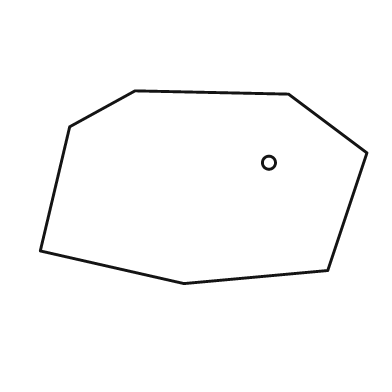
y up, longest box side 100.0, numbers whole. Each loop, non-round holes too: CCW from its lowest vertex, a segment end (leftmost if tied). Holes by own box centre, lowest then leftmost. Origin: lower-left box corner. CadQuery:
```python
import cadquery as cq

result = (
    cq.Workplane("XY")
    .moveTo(44.0, 0.0)
    .lineTo(88.0, 4.0)
    .lineTo(100.0, 40.0)
    .lineTo(76.0, 58.0)
    .lineTo(29.0, 59.0)
    .lineTo(9.0, 48.0)
    .lineTo(0.0, 10.0)
    .close()
    .moveTo(70.0, 37.0)
    .circle(2.0)
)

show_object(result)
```